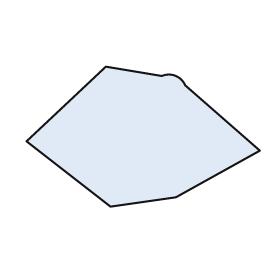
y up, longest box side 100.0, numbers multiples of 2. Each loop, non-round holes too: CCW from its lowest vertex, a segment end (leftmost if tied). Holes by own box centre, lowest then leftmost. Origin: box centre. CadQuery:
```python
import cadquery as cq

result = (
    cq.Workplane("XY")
    .moveTo(-14.0, -30.0)
    .lineTo(14.0, -26.0)
    .lineTo(50.0, -6.0)
    .lineTo(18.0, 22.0)
    .threePointArc((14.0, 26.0), (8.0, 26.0))
    .lineTo(-16.0, 30.0)
    .lineTo(-50.0, -2.0)
    .close()
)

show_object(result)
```